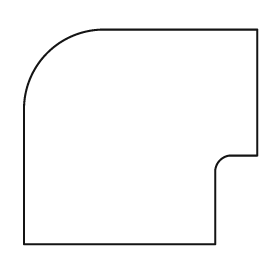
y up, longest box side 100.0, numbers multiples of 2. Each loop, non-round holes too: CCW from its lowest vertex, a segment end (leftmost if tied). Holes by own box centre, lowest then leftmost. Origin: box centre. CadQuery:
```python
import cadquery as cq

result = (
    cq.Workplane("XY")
    .moveTo(-50.0, -46.0)
    .lineTo(32.0, -46.0)
    .lineTo(32.0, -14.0)
    .threePointArc((34.0, -10.0), (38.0, -8.0))
    .lineTo(50.0, -8.0)
    .lineTo(50.0, 46.0)
    .lineTo(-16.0, 46.0)
    .threePointArc((-40.0, 36.0), (-50.0, 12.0))
    .close()
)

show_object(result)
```